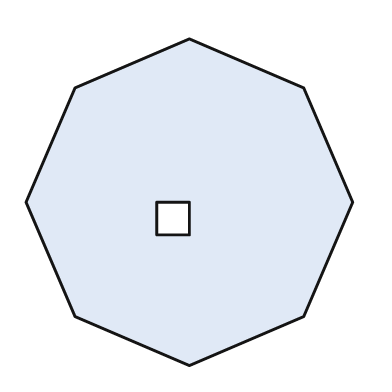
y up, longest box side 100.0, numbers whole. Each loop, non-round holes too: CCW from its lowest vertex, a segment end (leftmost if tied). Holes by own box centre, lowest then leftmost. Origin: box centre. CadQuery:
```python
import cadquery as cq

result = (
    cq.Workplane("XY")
    .moveTo(0.0, -50.0)
    .lineTo(35.0, -35.0)
    .lineTo(50.0, 0.0)
    .lineTo(35.0, 35.0)
    .lineTo(0.0, 50.0)
    .lineTo(-35.0, 35.0)
    .lineTo(-50.0, 0.0)
    .lineTo(-35.0, -35.0)
    .close()
    .moveTo(-10.0, -10.0)
    .lineTo(0.0, -10.0)
    .lineTo(0.0, 0.0)
    .lineTo(-10.0, 0.0)
    .close()
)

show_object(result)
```